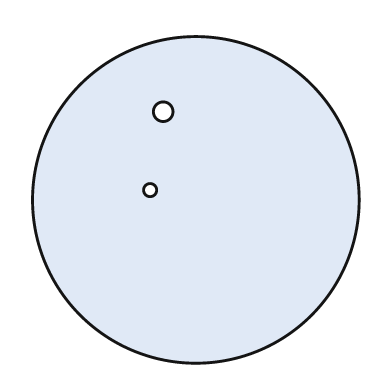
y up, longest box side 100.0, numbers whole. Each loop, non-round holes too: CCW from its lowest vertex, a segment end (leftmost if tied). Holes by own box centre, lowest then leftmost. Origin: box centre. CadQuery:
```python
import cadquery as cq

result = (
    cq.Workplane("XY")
    .moveTo(0.0, 0.0)
    .circle(50.0)
    .moveTo(-14.0, 3.0)
    .circle(2.0)
    .moveTo(-10.0, 27.0)
    .circle(3.0)
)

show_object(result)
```